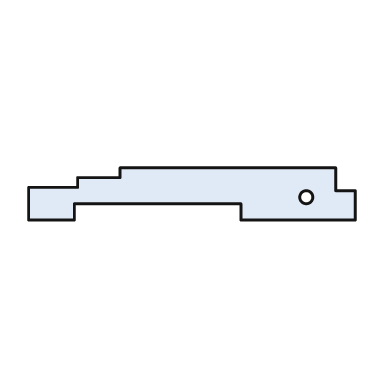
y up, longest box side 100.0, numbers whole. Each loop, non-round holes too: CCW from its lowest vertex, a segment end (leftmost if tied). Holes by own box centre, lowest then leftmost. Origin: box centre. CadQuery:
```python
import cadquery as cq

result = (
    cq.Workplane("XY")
    .moveTo(-50.0, -8.0)
    .lineTo(-36.0, -8.0)
    .lineTo(-36.0, -3.0)
    .lineTo(15.0, -3.0)
    .lineTo(15.0, -8.0)
    .lineTo(50.0, -8.0)
    .lineTo(50.0, 1.0)
    .lineTo(44.0, 1.0)
    .lineTo(44.0, 8.0)
    .lineTo(-22.0, 8.0)
    .lineTo(-22.0, 5.0)
    .lineTo(-35.0, 5.0)
    .lineTo(-35.0, 2.0)
    .lineTo(-50.0, 2.0)
    .close()
    .moveTo(35.0, -1.0)
    .circle(2.0)
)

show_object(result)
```